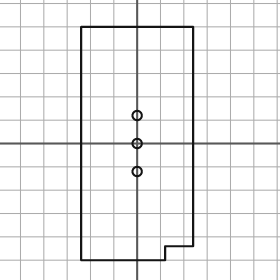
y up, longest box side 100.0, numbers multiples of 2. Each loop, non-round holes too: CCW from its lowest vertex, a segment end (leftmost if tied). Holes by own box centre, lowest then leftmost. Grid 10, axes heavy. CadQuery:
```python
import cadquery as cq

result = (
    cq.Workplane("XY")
    .moveTo(-24.0, -50.0)
    .lineTo(12.0, -50.0)
    .lineTo(12.0, -44.0)
    .lineTo(24.0, -44.0)
    .lineTo(24.0, 50.0)
    .lineTo(-24.0, 50.0)
    .close()
    .moveTo(0.0, -12.0)
    .circle(2.0)
    .moveTo(0.0, 0.0)
    .circle(2.0)
    .moveTo(0.0, 12.0)
    .circle(2.0)
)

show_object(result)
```